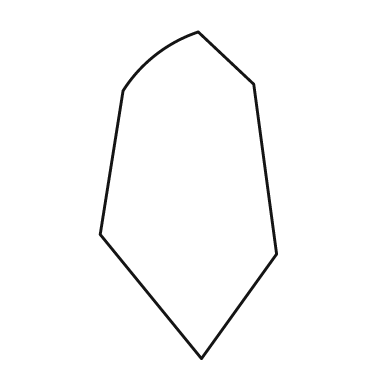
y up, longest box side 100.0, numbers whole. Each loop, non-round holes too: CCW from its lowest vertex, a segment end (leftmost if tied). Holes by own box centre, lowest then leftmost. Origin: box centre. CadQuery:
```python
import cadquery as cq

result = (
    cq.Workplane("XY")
    .moveTo(4.0, -50.0)
    .lineTo(27.0, -18.0)
    .lineTo(20.0, 34.0)
    .lineTo(3.0, 50.0)
    .threePointArc((-10.0, 43.0), (-20.0, 32.0))
    .lineTo(-27.0, -12.0)
    .close()
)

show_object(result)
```